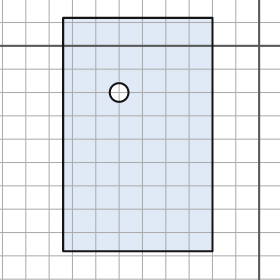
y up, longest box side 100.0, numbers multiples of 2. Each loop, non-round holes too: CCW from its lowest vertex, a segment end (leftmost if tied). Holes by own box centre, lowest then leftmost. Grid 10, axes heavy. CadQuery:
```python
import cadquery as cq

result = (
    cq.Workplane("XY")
    .moveTo(-84.0, -88.0)
    .lineTo(-20.0, -88.0)
    .lineTo(-20.0, 12.0)
    .lineTo(-84.0, 12.0)
    .close()
    .moveTo(-60.0, -20.0)
    .circle(4.0)
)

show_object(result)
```